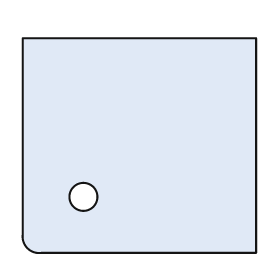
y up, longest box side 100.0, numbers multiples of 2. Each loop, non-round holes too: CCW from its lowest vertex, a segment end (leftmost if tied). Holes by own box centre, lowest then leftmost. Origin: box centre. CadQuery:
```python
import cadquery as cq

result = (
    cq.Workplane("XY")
    .moveTo(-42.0, -46.0)
    .lineTo(50.0, -46.0)
    .lineTo(50.0, 46.0)
    .lineTo(-50.0, 46.0)
    .lineTo(-50.0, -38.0)
    .threePointArc((-48.0, -44.0), (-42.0, -46.0))
    .close()
    .moveTo(-24.0, -22.0)
    .circle(6.0)
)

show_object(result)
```